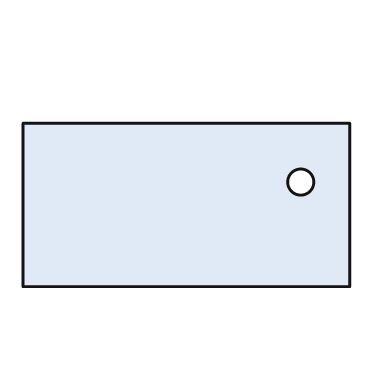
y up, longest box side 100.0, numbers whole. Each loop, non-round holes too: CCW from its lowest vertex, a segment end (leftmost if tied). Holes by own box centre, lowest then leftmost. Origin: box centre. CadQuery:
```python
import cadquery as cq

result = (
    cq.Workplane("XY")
    .moveTo(-50.0, -25.0)
    .lineTo(50.0, -25.0)
    .lineTo(50.0, 25.0)
    .lineTo(-50.0, 25.0)
    .close()
    .moveTo(35.0, 7.0)
    .circle(4.0)
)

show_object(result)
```